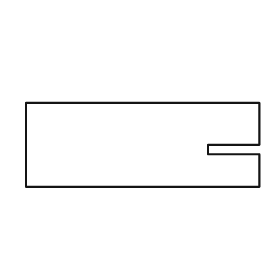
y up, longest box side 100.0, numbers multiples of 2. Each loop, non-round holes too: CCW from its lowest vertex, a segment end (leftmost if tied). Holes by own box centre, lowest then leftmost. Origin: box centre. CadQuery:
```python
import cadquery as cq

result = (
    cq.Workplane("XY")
    .moveTo(-50.0, -18.0)
    .lineTo(50.0, -18.0)
    .lineTo(50.0, -4.0)
    .lineTo(28.0, -4.0)
    .lineTo(28.0, 0.0)
    .lineTo(50.0, 0.0)
    .lineTo(50.0, 18.0)
    .lineTo(-50.0, 18.0)
    .close()
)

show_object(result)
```